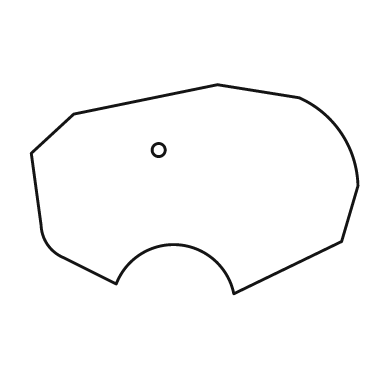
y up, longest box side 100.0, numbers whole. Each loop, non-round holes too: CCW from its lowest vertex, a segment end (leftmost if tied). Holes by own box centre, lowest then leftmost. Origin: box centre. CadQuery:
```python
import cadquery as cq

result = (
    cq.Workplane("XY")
    .moveTo(12.0, -32.0)
    .lineTo(45.0, -16.0)
    .lineTo(50.0, 1.0)
    .threePointArc((45.0, 17.0), (32.0, 28.0))
    .lineTo(7.0, 32.0)
    .lineTo(-37.0, 23.0)
    .lineTo(-50.0, 11.0)
    .lineTo(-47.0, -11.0)
    .threePointArc((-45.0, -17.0), (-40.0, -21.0))
    .lineTo(-24.0, -29.0)
    .threePointArc((-5.0, -17.0), (12.0, -32.0))
    .close()
    .moveTo(-11.0, 12.0)
    .circle(2.0)
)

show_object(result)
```